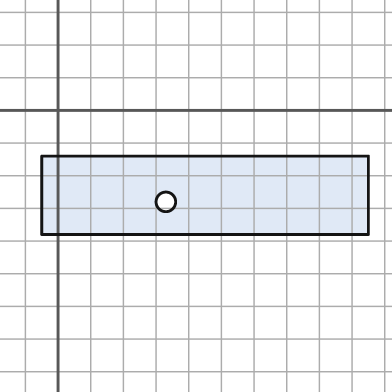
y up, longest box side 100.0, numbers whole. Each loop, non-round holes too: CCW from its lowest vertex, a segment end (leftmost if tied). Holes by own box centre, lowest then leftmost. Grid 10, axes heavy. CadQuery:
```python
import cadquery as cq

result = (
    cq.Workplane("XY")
    .moveTo(-5.0, -38.0)
    .lineTo(95.0, -38.0)
    .lineTo(95.0, -14.0)
    .lineTo(-5.0, -14.0)
    .close()
    .moveTo(33.0, -28.0)
    .circle(3.0)
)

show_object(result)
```